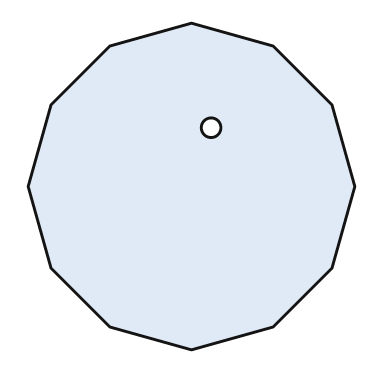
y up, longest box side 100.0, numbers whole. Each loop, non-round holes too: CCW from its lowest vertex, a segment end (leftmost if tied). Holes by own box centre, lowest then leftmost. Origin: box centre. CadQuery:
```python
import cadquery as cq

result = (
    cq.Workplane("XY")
    .moveTo(0.0, -50.0)
    .lineTo(25.0, -43.0)
    .lineTo(43.0, -25.0)
    .lineTo(50.0, 0.0)
    .lineTo(43.0, 25.0)
    .lineTo(25.0, 43.0)
    .lineTo(0.0, 50.0)
    .lineTo(-25.0, 43.0)
    .lineTo(-43.0, 25.0)
    .lineTo(-50.0, 0.0)
    .lineTo(-43.0, -25.0)
    .lineTo(-25.0, -43.0)
    .close()
    .moveTo(6.0, 18.0)
    .circle(3.0)
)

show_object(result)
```